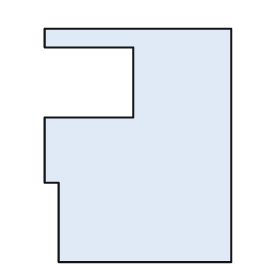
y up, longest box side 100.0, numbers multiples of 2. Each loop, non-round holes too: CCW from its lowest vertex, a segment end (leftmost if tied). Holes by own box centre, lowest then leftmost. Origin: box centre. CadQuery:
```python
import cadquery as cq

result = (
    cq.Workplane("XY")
    .moveTo(-34.0, -50.0)
    .lineTo(40.0, -50.0)
    .lineTo(40.0, 50.0)
    .lineTo(-40.0, 50.0)
    .lineTo(-40.0, 42.0)
    .lineTo(-2.0, 42.0)
    .lineTo(-2.0, 12.0)
    .lineTo(-40.0, 12.0)
    .lineTo(-40.0, -16.0)
    .lineTo(-34.0, -16.0)
    .close()
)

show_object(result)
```